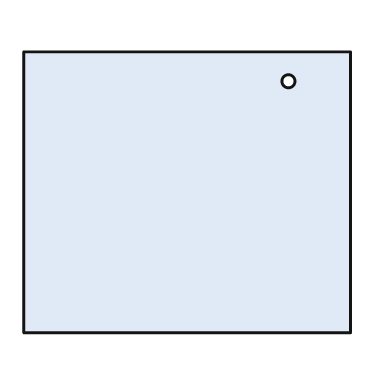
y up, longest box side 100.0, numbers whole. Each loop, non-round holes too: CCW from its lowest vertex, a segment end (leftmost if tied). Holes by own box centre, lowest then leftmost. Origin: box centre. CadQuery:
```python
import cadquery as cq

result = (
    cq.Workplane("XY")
    .moveTo(-50.0, -43.0)
    .lineTo(50.0, -43.0)
    .lineTo(50.0, 43.0)
    .lineTo(-50.0, 43.0)
    .close()
    .moveTo(31.0, 34.0)
    .circle(2.0)
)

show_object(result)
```